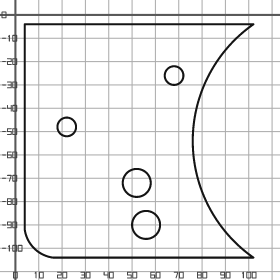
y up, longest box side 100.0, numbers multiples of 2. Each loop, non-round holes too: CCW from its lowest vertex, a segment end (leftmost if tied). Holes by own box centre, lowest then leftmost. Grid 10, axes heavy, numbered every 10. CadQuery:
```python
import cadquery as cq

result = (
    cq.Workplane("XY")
    .moveTo(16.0, -104.0)
    .lineTo(102.0, -104.0)
    .threePointArc((76.0, -54.0), (102.0, -4.0))
    .lineTo(4.0, -4.0)
    .lineTo(4.0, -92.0)
    .threePointArc((8.0, -100.0), (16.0, -104.0))
    .close()
    .moveTo(56.0, -90.0)
    .circle(6.0)
    .moveTo(52.0, -72.0)
    .circle(6.0)
    .moveTo(22.0, -48.0)
    .circle(4.0)
    .moveTo(68.0, -26.0)
    .circle(4.0)
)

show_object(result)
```